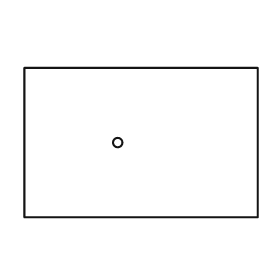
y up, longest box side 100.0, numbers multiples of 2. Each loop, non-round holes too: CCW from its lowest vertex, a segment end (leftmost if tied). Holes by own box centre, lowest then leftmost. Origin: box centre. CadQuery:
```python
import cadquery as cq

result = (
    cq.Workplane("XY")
    .moveTo(-50.0, -32.0)
    .lineTo(50.0, -32.0)
    .lineTo(50.0, 32.0)
    .lineTo(-50.0, 32.0)
    .close()
    .moveTo(-10.0, 0.0)
    .circle(2.0)
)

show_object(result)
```